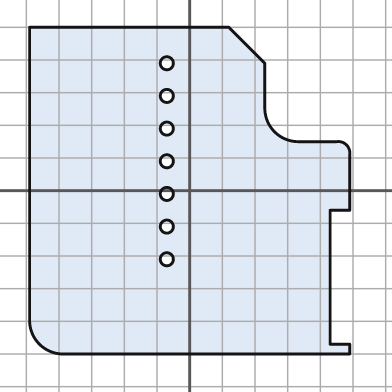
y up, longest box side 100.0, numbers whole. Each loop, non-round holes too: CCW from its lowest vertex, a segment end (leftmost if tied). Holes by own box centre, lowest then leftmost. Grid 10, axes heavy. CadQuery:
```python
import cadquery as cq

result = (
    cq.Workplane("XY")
    .moveTo(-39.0, -50.0)
    .lineTo(49.0, -50.0)
    .lineTo(49.0, -47.0)
    .lineTo(43.0, -47.0)
    .lineTo(43.0, -6.0)
    .lineTo(49.0, -6.0)
    .lineTo(49.0, 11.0)
    .threePointArc((48.0, 14.0), (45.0, 15.0))
    .lineTo(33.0, 15.0)
    .threePointArc((26.0, 18.0), (23.0, 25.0))
    .lineTo(23.0, 39.0)
    .lineTo(12.0, 50.0)
    .lineTo(-49.0, 50.0)
    .lineTo(-49.0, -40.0)
    .threePointArc((-46.0, -47.0), (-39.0, -50.0))
    .close()
    .moveTo(-7.0, -21.0)
    .circle(2.0)
    .moveTo(-7.0, -11.0)
    .circle(2.0)
    .moveTo(-7.0, -1.0)
    .circle(2.0)
    .moveTo(-7.0, 9.0)
    .circle(2.0)
    .moveTo(-7.0, 19.0)
    .circle(2.0)
    .moveTo(-7.0, 29.0)
    .circle(2.0)
    .moveTo(-7.0, 39.0)
    .circle(2.0)
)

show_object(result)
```